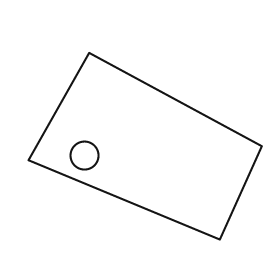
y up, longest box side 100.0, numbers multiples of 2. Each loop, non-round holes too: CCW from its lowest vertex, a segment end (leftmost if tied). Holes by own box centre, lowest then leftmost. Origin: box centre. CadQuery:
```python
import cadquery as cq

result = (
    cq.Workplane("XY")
    .moveTo(32.0, -40.0)
    .lineTo(50.0, 0.0)
    .lineTo(-24.0, 40.0)
    .lineTo(-50.0, -6.0)
    .close()
    .moveTo(-26.0, -4.0)
    .circle(6.0)
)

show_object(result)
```